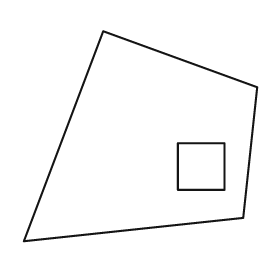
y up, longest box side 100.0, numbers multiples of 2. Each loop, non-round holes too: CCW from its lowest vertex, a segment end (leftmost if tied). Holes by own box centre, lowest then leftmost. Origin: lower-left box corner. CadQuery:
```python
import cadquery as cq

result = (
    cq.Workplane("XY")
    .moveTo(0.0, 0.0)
    .lineTo(94.0, 10.0)
    .lineTo(100.0, 66.0)
    .lineTo(34.0, 90.0)
    .close()
    .moveTo(66.0, 22.0)
    .lineTo(86.0, 22.0)
    .lineTo(86.0, 42.0)
    .lineTo(66.0, 42.0)
    .close()
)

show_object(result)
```